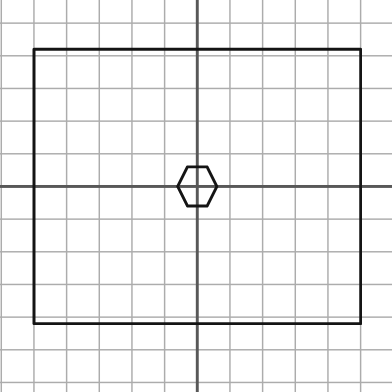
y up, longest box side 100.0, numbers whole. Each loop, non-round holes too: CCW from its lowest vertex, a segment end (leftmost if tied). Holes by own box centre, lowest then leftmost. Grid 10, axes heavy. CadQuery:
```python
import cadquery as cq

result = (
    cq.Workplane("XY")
    .moveTo(-50.0, -42.0)
    .lineTo(50.0, -42.0)
    .lineTo(50.0, 42.0)
    .lineTo(-50.0, 42.0)
    .close()
    .moveTo(-3.0, -6.0)
    .lineTo(3.0, -6.0)
    .lineTo(6.0, 0.0)
    .lineTo(3.0, 6.0)
    .lineTo(-3.0, 6.0)
    .lineTo(-6.0, 0.0)
    .close()
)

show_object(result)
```